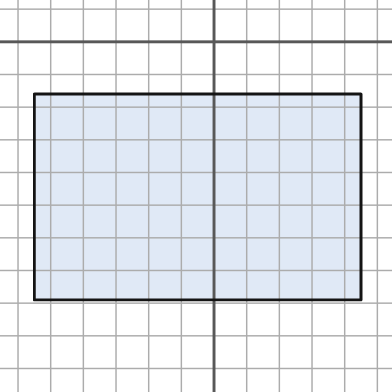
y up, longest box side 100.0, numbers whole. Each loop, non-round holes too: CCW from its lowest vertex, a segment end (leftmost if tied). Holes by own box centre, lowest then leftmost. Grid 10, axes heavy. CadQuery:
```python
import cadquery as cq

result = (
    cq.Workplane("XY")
    .moveTo(-55.0, -79.0)
    .lineTo(45.0, -79.0)
    .lineTo(45.0, -16.0)
    .lineTo(-55.0, -16.0)
    .close()
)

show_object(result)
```